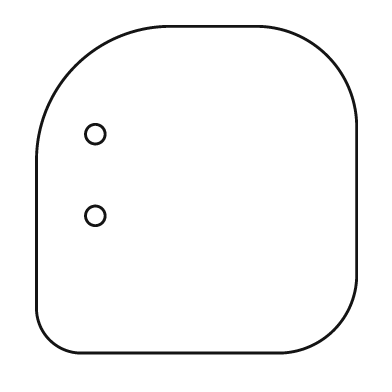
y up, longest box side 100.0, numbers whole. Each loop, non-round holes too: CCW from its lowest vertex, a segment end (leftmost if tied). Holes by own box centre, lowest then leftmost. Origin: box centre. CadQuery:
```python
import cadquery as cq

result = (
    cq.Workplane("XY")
    .moveTo(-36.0, -50.0)
    .lineTo(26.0, -50.0)
    .threePointArc((42.0, -43.0), (49.0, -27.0))
    .lineTo(49.0, 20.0)
    .threePointArc((40.0, 41.0), (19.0, 50.0))
    .lineTo(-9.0, 50.0)
    .threePointArc((-37.0, 38.0), (-49.0, 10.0))
    .lineTo(-49.0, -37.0)
    .threePointArc((-45.0, -46.0), (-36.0, -50.0))
    .close()
    .moveTo(-31.0, -8.0)
    .circle(3.0)
    .moveTo(-31.0, 17.0)
    .circle(3.0)
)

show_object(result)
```